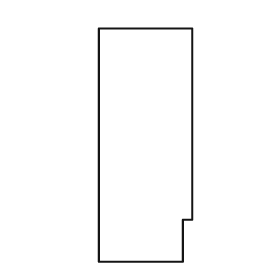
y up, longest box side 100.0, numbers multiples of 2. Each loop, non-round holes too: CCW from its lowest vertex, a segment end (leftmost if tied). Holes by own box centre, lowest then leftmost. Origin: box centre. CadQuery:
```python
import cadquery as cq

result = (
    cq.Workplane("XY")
    .moveTo(-20.0, -50.0)
    .lineTo(16.0, -50.0)
    .lineTo(16.0, -32.0)
    .lineTo(20.0, -32.0)
    .lineTo(20.0, 50.0)
    .lineTo(-20.0, 50.0)
    .close()
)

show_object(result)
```